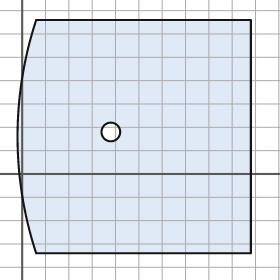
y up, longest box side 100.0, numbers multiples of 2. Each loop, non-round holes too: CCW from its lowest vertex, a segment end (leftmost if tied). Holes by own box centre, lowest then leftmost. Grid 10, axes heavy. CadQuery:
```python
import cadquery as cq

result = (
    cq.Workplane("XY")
    .moveTo(6.0, -34.0)
    .lineTo(98.0, -34.0)
    .lineTo(98.0, 66.0)
    .lineTo(6.0, 66.0)
    .threePointArc((-2.0, 16.0), (6.0, -34.0))
    .close()
    .moveTo(38.0, 18.0)
    .circle(4.0)
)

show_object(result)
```